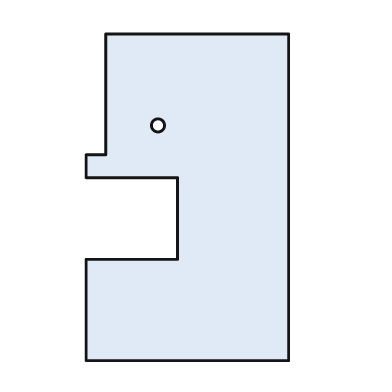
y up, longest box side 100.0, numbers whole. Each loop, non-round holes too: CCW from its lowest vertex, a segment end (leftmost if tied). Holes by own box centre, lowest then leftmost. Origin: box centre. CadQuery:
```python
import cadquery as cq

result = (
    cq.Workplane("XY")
    .moveTo(-31.0, -50.0)
    .lineTo(31.0, -50.0)
    .lineTo(31.0, 50.0)
    .lineTo(-25.0, 50.0)
    .lineTo(-25.0, 13.0)
    .lineTo(-31.0, 13.0)
    .lineTo(-31.0, 6.0)
    .lineTo(-3.0, 6.0)
    .lineTo(-3.0, -19.0)
    .lineTo(-31.0, -19.0)
    .close()
    .moveTo(-9.0, 22.0)
    .circle(2.0)
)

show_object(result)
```